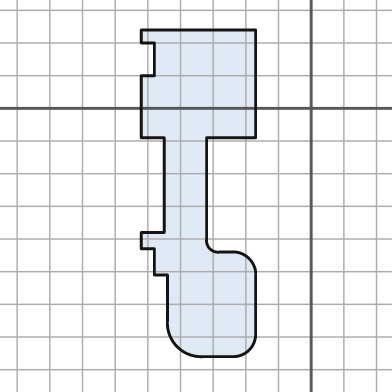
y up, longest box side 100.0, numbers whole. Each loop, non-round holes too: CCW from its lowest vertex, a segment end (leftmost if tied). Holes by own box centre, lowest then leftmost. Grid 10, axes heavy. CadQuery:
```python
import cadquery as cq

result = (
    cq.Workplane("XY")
    .moveTo(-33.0, -76.0)
    .lineTo(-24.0, -76.0)
    .threePointArc((-19.0, -74.0), (-17.0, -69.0))
    .lineTo(-17.0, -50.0)
    .threePointArc((-19.0, -46.0), (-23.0, -44.0))
    .lineTo(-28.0, -44.0)
    .threePointArc((-31.0, -43.0), (-32.0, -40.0))
    .lineTo(-32.0, -9.0)
    .lineTo(-17.0, -9.0)
    .lineTo(-17.0, 24.0)
    .lineTo(-52.0, 24.0)
    .lineTo(-52.0, 20.0)
    .lineTo(-48.0, 20.0)
    .lineTo(-48.0, 10.0)
    .lineTo(-52.0, 10.0)
    .lineTo(-52.0, -9.0)
    .lineTo(-45.0, -9.0)
    .lineTo(-45.0, -38.0)
    .lineTo(-52.0, -38.0)
    .lineTo(-52.0, -43.0)
    .lineTo(-48.0, -43.0)
    .lineTo(-48.0, -51.0)
    .lineTo(-44.0, -51.0)
    .lineTo(-44.0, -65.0)
    .threePointArc((-41.0, -73.0), (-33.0, -76.0))
    .close()
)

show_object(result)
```